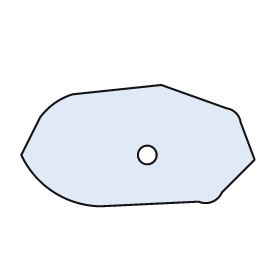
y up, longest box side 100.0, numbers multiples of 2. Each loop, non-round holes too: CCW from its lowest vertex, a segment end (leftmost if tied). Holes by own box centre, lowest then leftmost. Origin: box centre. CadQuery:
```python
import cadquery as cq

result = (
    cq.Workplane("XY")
    .moveTo(-16.0, -26.0)
    .lineTo(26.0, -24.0)
    .threePointArc((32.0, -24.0), (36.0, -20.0))
    .lineTo(50.0, -6.0)
    .lineTo(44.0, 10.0)
    .threePointArc((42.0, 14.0), (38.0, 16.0))
    .lineTo(10.0, 26.0)
    .lineTo(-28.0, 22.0)
    .threePointArc((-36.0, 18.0), (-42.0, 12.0))
    .lineTo(-50.0, -4.0)
    .threePointArc((-36.0, -20.0), (-16.0, -26.0))
    .close()
    .moveTo(4.0, -4.0)
    .circle(4.0)
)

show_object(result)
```